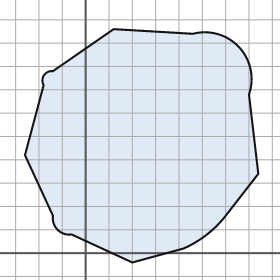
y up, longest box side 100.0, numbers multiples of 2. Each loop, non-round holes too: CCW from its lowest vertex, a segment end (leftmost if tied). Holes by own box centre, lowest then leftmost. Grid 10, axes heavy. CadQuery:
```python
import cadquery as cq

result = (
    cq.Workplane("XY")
    .moveTo(20.0, -4.0)
    .lineTo(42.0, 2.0)
    .threePointArc((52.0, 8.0), (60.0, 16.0))
    .lineTo(74.0, 34.0)
    .lineTo(70.0, 68.0)
    .threePointArc((66.0, 88.0), (46.0, 94.0))
    .lineTo(12.0, 96.0)
    .lineTo(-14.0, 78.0)
    .threePointArc((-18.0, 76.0), (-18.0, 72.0))
    .lineTo(-26.0, 42.0)
    .lineTo(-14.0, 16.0)
    .threePointArc((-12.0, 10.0), (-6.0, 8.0))
    .close()
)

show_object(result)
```